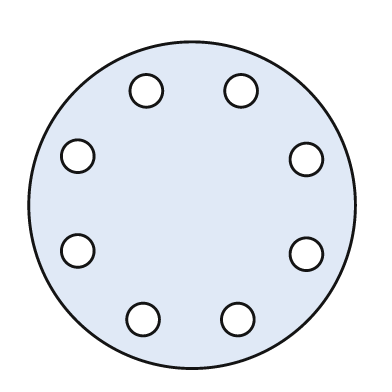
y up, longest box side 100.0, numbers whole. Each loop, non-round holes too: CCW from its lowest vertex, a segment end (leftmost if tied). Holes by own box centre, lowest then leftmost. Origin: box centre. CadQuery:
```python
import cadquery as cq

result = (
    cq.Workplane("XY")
    .moveTo(0.0, 0.0)
    .circle(50.0)
    .moveTo(-15.0, -35.0)
    .circle(5.0)
    .moveTo(14.0, -35.0)
    .circle(5.0)
    .moveTo(35.0, -15.0)
    .circle(5.0)
    .moveTo(-35.0, -14.0)
    .circle(5.0)
    .moveTo(35.0, 14.0)
    .circle(5.0)
    .moveTo(-35.0, 15.0)
    .circle(5.0)
    .moveTo(-14.0, 35.0)
    .circle(5.0)
    .moveTo(15.0, 35.0)
    .circle(5.0)
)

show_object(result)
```